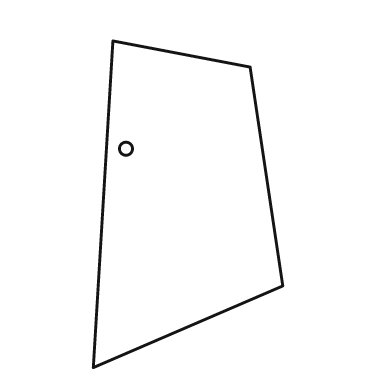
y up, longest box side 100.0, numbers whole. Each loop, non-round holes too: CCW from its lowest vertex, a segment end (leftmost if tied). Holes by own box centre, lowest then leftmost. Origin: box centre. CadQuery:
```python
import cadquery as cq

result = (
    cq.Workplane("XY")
    .moveTo(-29.0, -50.0)
    .lineTo(29.0, -25.0)
    .lineTo(19.0, 42.0)
    .lineTo(-23.0, 50.0)
    .close()
    .moveTo(-19.0, 17.0)
    .circle(2.0)
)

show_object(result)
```